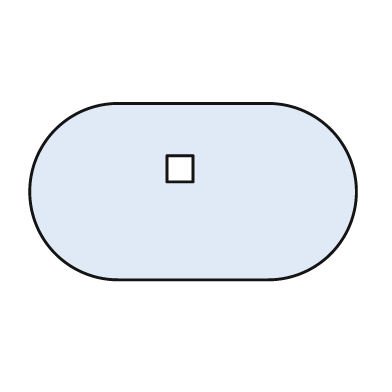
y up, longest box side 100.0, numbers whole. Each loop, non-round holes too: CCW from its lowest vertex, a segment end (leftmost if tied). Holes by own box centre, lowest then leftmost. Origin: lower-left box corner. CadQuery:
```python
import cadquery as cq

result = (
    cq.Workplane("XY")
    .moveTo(27.0, 0.0)
    .lineTo(73.0, 0.0)
    .threePointArc((100.0, 27.0), (73.0, 54.0))
    .lineTo(27.0, 54.0)
    .threePointArc((0.0, 27.0), (27.0, 0.0))
    .close()
    .moveTo(42.0, 30.0)
    .lineTo(50.0, 30.0)
    .lineTo(50.0, 38.0)
    .lineTo(42.0, 38.0)
    .close()
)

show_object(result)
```